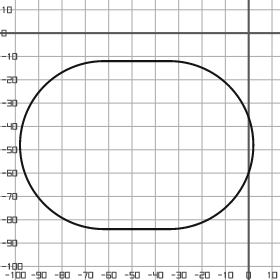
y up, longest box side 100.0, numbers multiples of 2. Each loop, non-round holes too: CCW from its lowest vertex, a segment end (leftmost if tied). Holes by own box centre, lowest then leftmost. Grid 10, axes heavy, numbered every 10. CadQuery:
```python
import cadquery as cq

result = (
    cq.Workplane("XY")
    .moveTo(-62.0, -84.0)
    .lineTo(-34.0, -84.0)
    .threePointArc((2.0, -48.0), (-34.0, -12.0))
    .lineTo(-62.0, -12.0)
    .threePointArc((-98.0, -48.0), (-62.0, -84.0))
    .close()
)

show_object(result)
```